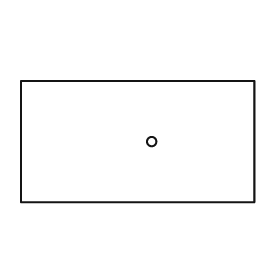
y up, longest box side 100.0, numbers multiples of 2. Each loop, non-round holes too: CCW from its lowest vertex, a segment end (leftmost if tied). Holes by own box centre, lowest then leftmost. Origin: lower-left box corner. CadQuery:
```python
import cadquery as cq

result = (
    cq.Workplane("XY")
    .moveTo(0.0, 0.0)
    .lineTo(100.0, 0.0)
    .lineTo(100.0, 52.0)
    .lineTo(0.0, 52.0)
    .close()
    .moveTo(56.0, 26.0)
    .circle(2.0)
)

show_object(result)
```